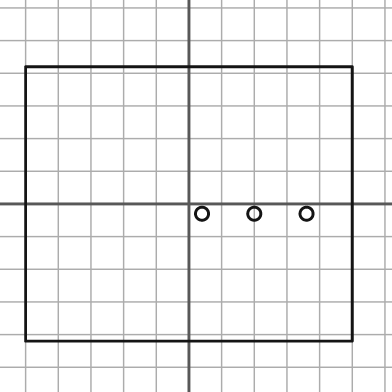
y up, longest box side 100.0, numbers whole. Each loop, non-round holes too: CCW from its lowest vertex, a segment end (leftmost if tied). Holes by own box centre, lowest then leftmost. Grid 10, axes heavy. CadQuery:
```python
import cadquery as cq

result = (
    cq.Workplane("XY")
    .moveTo(-50.0, -42.0)
    .lineTo(50.0, -42.0)
    .lineTo(50.0, 42.0)
    .lineTo(-50.0, 42.0)
    .close()
    .moveTo(4.0, -3.0)
    .circle(2.0)
    .moveTo(20.0, -3.0)
    .circle(2.0)
    .moveTo(36.0, -3.0)
    .circle(2.0)
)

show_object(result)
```